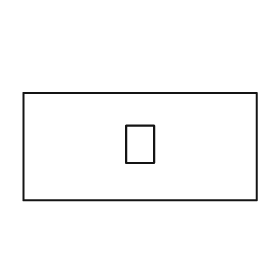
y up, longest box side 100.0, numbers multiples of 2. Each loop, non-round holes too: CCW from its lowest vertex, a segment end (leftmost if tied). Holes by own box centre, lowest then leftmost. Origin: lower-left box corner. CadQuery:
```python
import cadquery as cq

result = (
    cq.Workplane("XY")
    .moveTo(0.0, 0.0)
    .lineTo(100.0, 0.0)
    .lineTo(100.0, 46.0)
    .lineTo(0.0, 46.0)
    .close()
    .moveTo(44.0, 16.0)
    .lineTo(56.0, 16.0)
    .lineTo(56.0, 32.0)
    .lineTo(44.0, 32.0)
    .close()
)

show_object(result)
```